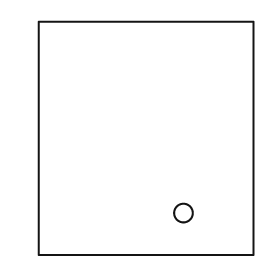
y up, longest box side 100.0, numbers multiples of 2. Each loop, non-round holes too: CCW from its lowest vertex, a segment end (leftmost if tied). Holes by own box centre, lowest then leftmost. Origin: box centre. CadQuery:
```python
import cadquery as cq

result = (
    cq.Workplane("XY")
    .moveTo(-46.0, -50.0)
    .lineTo(46.0, -50.0)
    .lineTo(46.0, 50.0)
    .lineTo(-46.0, 50.0)
    .close()
    .moveTo(16.0, -32.0)
    .circle(4.0)
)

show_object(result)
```